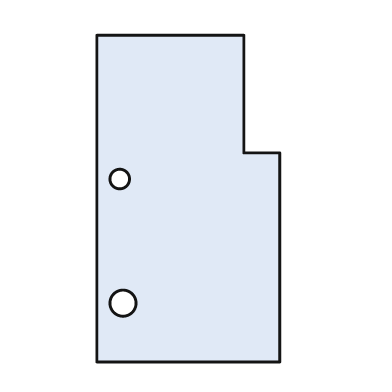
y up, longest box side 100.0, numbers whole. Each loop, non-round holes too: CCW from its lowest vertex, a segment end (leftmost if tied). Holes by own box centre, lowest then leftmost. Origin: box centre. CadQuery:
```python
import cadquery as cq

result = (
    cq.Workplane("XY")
    .moveTo(-28.0, -50.0)
    .lineTo(28.0, -50.0)
    .lineTo(28.0, 14.0)
    .lineTo(17.0, 14.0)
    .lineTo(17.0, 50.0)
    .lineTo(-28.0, 50.0)
    .close()
    .moveTo(-20.0, -32.0)
    .circle(4.0)
    .moveTo(-21.0, 6.0)
    .circle(3.0)
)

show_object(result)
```